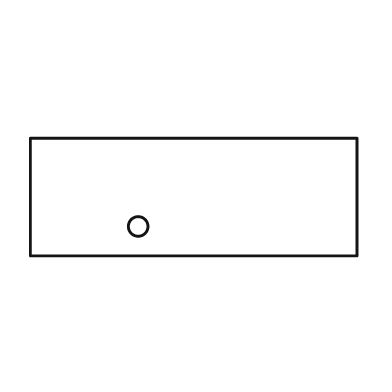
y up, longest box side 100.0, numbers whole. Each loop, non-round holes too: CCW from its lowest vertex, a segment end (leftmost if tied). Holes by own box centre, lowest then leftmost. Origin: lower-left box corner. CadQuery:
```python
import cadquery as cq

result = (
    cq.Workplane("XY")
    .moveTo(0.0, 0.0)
    .lineTo(100.0, 0.0)
    .lineTo(100.0, 36.0)
    .lineTo(0.0, 36.0)
    .close()
    .moveTo(33.0, 9.0)
    .circle(3.0)
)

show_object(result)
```